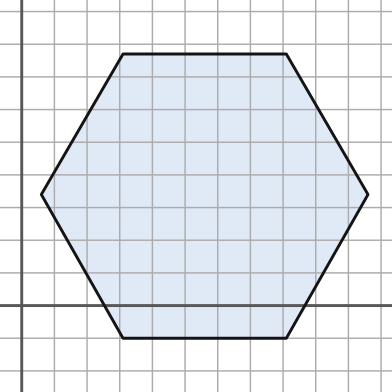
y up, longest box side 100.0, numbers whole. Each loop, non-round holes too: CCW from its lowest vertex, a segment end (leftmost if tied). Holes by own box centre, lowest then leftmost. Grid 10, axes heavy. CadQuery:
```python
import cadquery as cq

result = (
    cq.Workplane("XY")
    .moveTo(31.0, -10.0)
    .lineTo(81.0, -10.0)
    .lineTo(106.0, 34.0)
    .lineTo(81.0, 77.0)
    .lineTo(31.0, 77.0)
    .lineTo(6.0, 34.0)
    .close()
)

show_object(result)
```